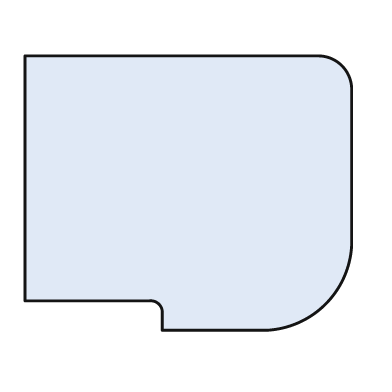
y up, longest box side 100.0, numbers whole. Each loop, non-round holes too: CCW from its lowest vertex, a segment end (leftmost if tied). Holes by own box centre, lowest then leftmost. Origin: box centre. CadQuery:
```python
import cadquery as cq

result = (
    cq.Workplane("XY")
    .moveTo(-8.0, -42.0)
    .lineTo(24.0, -42.0)
    .threePointArc((42.0, -34.0), (50.0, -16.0))
    .lineTo(50.0, 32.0)
    .threePointArc((47.0, 39.0), (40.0, 42.0))
    .lineTo(-50.0, 42.0)
    .lineTo(-50.0, -33.0)
    .lineTo(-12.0, -33.0)
    .threePointArc((-9.0, -34.0), (-8.0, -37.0))
    .close()
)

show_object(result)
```